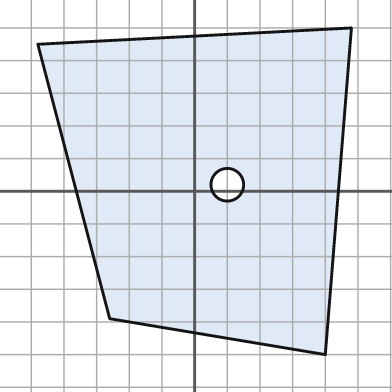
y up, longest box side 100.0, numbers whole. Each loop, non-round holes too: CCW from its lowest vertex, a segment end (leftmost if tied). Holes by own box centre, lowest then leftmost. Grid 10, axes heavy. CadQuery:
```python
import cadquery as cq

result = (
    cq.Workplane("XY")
    .moveTo(40.0, -50.0)
    .lineTo(48.0, 50.0)
    .lineTo(-48.0, 45.0)
    .lineTo(-26.0, -39.0)
    .close()
    .moveTo(10.0, 2.0)
    .circle(5.0)
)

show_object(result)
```